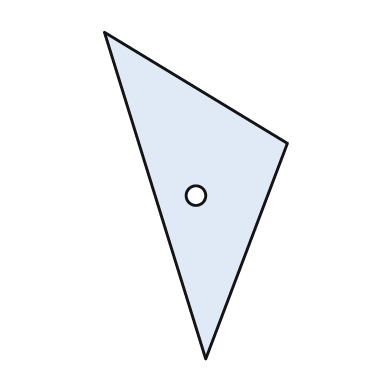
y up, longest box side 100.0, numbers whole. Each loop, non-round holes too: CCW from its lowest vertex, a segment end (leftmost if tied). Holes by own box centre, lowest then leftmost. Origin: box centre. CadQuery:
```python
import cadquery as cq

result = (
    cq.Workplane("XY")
    .moveTo(3.0, -50.0)
    .lineTo(28.0, 16.0)
    .lineTo(-28.0, 50.0)
    .close()
    .moveTo(0.0, 0.0)
    .circle(3.0)
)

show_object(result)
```